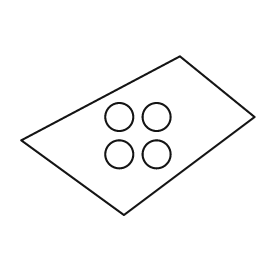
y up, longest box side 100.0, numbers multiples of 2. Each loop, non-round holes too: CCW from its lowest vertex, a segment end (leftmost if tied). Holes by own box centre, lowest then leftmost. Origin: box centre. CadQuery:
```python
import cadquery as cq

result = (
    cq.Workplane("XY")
    .moveTo(-6.0, -34.0)
    .lineTo(50.0, 8.0)
    .lineTo(18.0, 34.0)
    .lineTo(-50.0, -2.0)
    .close()
    .moveTo(-8.0, -8.0)
    .circle(6.0)
    .moveTo(8.0, -8.0)
    .circle(6.0)
    .moveTo(-8.0, 8.0)
    .circle(6.0)
    .moveTo(8.0, 8.0)
    .circle(6.0)
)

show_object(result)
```